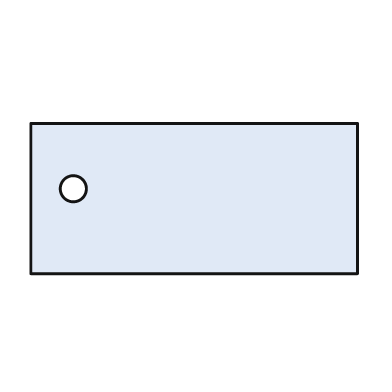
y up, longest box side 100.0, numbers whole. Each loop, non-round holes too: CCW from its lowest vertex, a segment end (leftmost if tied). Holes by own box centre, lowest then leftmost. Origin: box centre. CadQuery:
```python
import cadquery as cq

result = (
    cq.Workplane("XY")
    .moveTo(-50.0, -23.0)
    .lineTo(50.0, -23.0)
    .lineTo(50.0, 23.0)
    .lineTo(-50.0, 23.0)
    .close()
    .moveTo(-37.0, 3.0)
    .circle(4.0)
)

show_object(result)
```